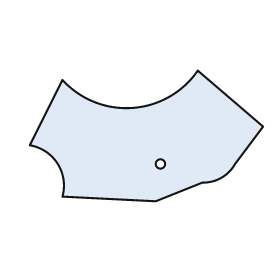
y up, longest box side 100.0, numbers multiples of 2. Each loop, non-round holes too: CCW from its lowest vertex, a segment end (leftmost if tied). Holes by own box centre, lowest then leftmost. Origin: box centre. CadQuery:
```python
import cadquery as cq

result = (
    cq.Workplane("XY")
    .moveTo(4.0, -28.0)
    .lineTo(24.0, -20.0)
    .threePointArc((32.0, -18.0), (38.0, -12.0))
    .lineTo(50.0, 4.0)
    .lineTo(22.0, 28.0)
    .threePointArc((-6.0, 12.0), (-36.0, 24.0))
    .lineTo(-50.0, -4.0)
    .threePointArc((-38.0, -12.0), (-36.0, -26.0))
    .close()
    .moveTo(6.0, -12.0)
    .circle(2.0)
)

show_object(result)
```